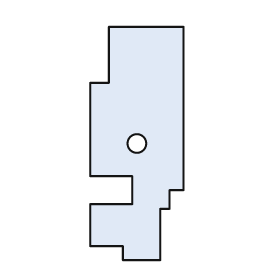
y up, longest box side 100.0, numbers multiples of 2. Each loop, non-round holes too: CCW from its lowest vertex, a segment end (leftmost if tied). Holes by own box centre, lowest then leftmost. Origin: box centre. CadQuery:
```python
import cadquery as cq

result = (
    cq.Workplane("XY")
    .moveTo(-6.0, -50.0)
    .lineTo(10.0, -50.0)
    .lineTo(10.0, -28.0)
    .lineTo(14.0, -28.0)
    .lineTo(14.0, -20.0)
    .lineTo(20.0, -20.0)
    .lineTo(20.0, 50.0)
    .lineTo(-12.0, 50.0)
    .lineTo(-12.0, 26.0)
    .lineTo(-20.0, 26.0)
    .lineTo(-20.0, -14.0)
    .lineTo(-2.0, -14.0)
    .lineTo(-2.0, -26.0)
    .lineTo(-20.0, -26.0)
    .lineTo(-20.0, -44.0)
    .lineTo(-6.0, -44.0)
    .close()
    .moveTo(0.0, 0.0)
    .circle(4.0)
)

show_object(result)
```